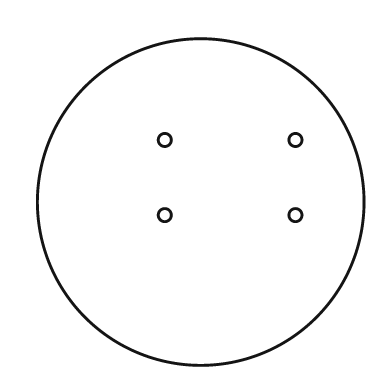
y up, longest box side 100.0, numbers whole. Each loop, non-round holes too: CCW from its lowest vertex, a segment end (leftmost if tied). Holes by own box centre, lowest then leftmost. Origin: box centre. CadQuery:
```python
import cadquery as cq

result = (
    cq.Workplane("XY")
    .moveTo(0.0, 0.0)
    .circle(50.0)
    .moveTo(-11.0, -4.0)
    .circle(2.0)
    .moveTo(29.0, -4.0)
    .circle(2.0)
    .moveTo(-11.0, 19.0)
    .circle(2.0)
    .moveTo(29.0, 19.0)
    .circle(2.0)
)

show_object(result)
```